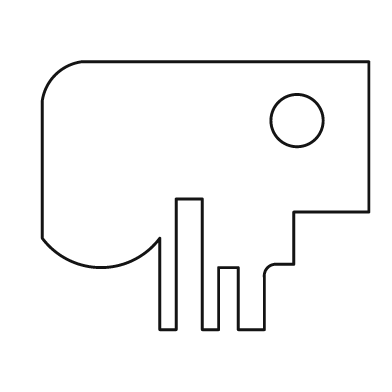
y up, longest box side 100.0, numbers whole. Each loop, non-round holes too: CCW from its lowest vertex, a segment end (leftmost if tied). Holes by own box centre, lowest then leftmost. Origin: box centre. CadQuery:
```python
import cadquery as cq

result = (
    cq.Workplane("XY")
    .moveTo(-14.0, -41.0)
    .lineTo(-9.0, -41.0)
    .lineTo(-9.0, -1.0)
    .lineTo(-1.0, -1.0)
    .lineTo(-1.0, -41.0)
    .lineTo(4.0, -41.0)
    .lineTo(4.0, -22.0)
    .lineTo(10.0, -22.0)
    .lineTo(10.0, -41.0)
    .lineTo(18.0, -41.0)
    .lineTo(18.0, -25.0)
    .threePointArc((19.0, -22.0), (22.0, -21.0))
    .lineTo(27.0, -21.0)
    .lineTo(27.0, -5.0)
    .lineTo(50.0, -5.0)
    .lineTo(50.0, 41.0)
    .lineTo(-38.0, 41.0)
    .threePointArc((-46.0, 37.0), (-50.0, 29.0))
    .lineTo(-50.0, -13.0)
    .threePointArc((-32.0, -22.0), (-14.0, -13.0))
    .close()
    .moveTo(28.0, 23.0)
    .circle(8.0)
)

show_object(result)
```